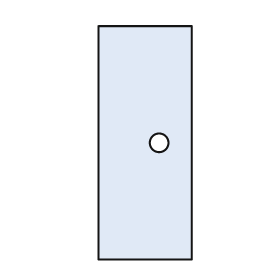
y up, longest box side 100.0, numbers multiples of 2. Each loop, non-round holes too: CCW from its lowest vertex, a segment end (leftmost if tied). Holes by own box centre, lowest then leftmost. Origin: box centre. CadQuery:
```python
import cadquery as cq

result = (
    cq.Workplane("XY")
    .moveTo(-20.0, -50.0)
    .lineTo(20.0, -50.0)
    .lineTo(20.0, 50.0)
    .lineTo(-20.0, 50.0)
    .close()
    .moveTo(6.0, 0.0)
    .circle(4.0)
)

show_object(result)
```